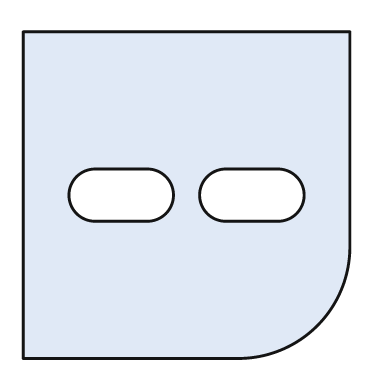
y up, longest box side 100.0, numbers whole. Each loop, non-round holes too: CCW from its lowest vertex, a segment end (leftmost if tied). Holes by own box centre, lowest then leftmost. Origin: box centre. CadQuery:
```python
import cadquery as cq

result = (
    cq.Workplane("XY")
    .moveTo(-50.0, -50.0)
    .lineTo(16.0, -50.0)
    .threePointArc((40.0, -40.0), (50.0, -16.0))
    .lineTo(50.0, 50.0)
    .lineTo(-50.0, 50.0)
    .close()
    .moveTo(-28.0, -8.0)
    .lineTo(-12.0, -8.0)
    .threePointArc((-4.0, 0.0), (-12.0, 8.0))
    .lineTo(-28.0, 8.0)
    .threePointArc((-36.0, 0.0), (-28.0, -8.0))
    .close()
    .moveTo(12.0, -8.0)
    .lineTo(28.0, -8.0)
    .threePointArc((36.0, 0.0), (28.0, 8.0))
    .lineTo(12.0, 8.0)
    .threePointArc((4.0, 0.0), (12.0, -8.0))
    .close()
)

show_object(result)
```